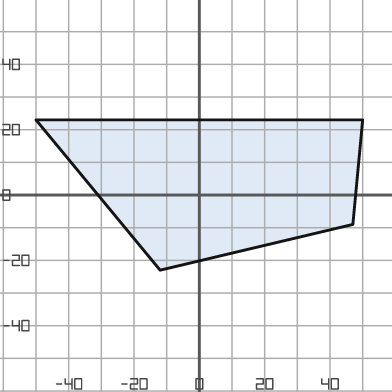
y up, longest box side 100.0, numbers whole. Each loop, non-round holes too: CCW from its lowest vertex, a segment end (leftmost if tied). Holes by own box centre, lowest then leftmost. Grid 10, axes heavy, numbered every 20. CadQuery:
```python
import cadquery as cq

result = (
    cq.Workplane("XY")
    .moveTo(-12.0, -23.0)
    .lineTo(47.0, -9.0)
    .lineTo(50.0, 23.0)
    .lineTo(-50.0, 23.0)
    .close()
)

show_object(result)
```